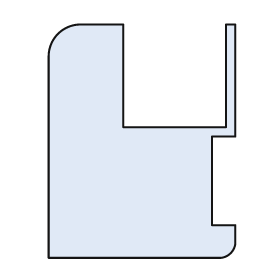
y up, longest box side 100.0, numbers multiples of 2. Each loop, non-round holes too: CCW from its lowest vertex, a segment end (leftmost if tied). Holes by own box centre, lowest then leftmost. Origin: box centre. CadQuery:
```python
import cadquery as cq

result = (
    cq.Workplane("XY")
    .moveTo(-40.0, -50.0)
    .lineTo(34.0, -50.0)
    .threePointArc((38.0, -48.0), (40.0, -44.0))
    .lineTo(40.0, -36.0)
    .lineTo(30.0, -36.0)
    .lineTo(30.0, 2.0)
    .lineTo(40.0, 2.0)
    .lineTo(40.0, 50.0)
    .lineTo(36.0, 50.0)
    .lineTo(36.0, 6.0)
    .lineTo(-8.0, 6.0)
    .lineTo(-8.0, 50.0)
    .lineTo(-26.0, 50.0)
    .threePointArc((-36.0, 46.0), (-40.0, 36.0))
    .close()
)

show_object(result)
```